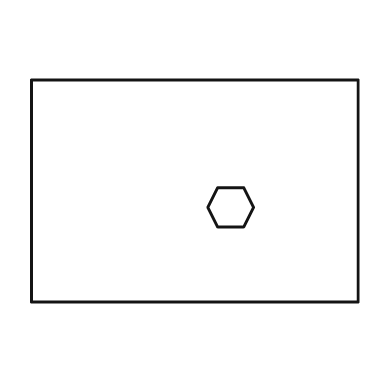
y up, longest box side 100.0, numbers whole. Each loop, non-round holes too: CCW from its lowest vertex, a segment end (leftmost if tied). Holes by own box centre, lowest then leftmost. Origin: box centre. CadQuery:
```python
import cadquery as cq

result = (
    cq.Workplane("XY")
    .moveTo(-50.0, -34.0)
    .lineTo(50.0, -34.0)
    .lineTo(50.0, 34.0)
    .lineTo(-50.0, 34.0)
    .close()
    .moveTo(7.0, -11.0)
    .lineTo(15.0, -11.0)
    .lineTo(18.0, -5.0)
    .lineTo(15.0, 1.0)
    .lineTo(7.0, 1.0)
    .lineTo(4.0, -5.0)
    .close()
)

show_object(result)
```